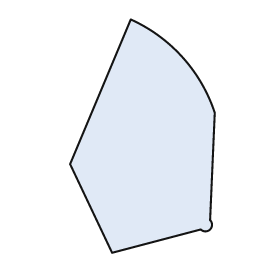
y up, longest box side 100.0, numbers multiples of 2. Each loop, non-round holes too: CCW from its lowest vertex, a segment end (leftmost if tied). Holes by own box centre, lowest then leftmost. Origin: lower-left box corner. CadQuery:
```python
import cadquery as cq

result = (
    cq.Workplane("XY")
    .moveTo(18.0, 0.0)
    .lineTo(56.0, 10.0)
    .threePointArc((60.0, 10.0), (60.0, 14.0))
    .lineTo(62.0, 60.0)
    .threePointArc((48.0, 84.0), (26.0, 100.0))
    .lineTo(0.0, 38.0)
    .close()
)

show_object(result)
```